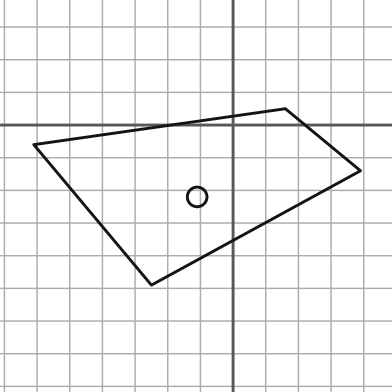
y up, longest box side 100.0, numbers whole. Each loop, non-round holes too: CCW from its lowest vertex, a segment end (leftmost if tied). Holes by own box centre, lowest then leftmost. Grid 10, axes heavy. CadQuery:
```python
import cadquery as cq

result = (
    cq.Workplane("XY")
    .moveTo(-25.0, -49.0)
    .lineTo(39.0, -14.0)
    .lineTo(16.0, 5.0)
    .lineTo(-61.0, -6.0)
    .close()
    .moveTo(-11.0, -22.0)
    .circle(3.0)
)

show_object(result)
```